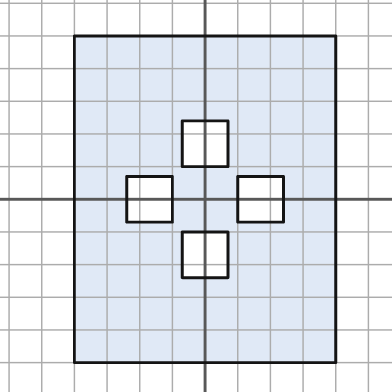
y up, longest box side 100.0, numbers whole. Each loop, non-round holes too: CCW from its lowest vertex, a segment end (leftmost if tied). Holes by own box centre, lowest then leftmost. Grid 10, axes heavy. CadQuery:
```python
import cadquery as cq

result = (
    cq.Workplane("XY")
    .moveTo(-40.0, -50.0)
    .lineTo(40.0, -50.0)
    .lineTo(40.0, 50.0)
    .lineTo(-40.0, 50.0)
    .close()
    .moveTo(-7.0, -24.0)
    .lineTo(7.0, -24.0)
    .lineTo(7.0, -10.0)
    .lineTo(-7.0, -10.0)
    .close()
    .moveTo(-24.0, -7.0)
    .lineTo(-10.0, -7.0)
    .lineTo(-10.0, 7.0)
    .lineTo(-24.0, 7.0)
    .close()
    .moveTo(10.0, -7.0)
    .lineTo(24.0, -7.0)
    .lineTo(24.0, 7.0)
    .lineTo(10.0, 7.0)
    .close()
    .moveTo(-7.0, 10.0)
    .lineTo(7.0, 10.0)
    .lineTo(7.0, 24.0)
    .lineTo(-7.0, 24.0)
    .close()
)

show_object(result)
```